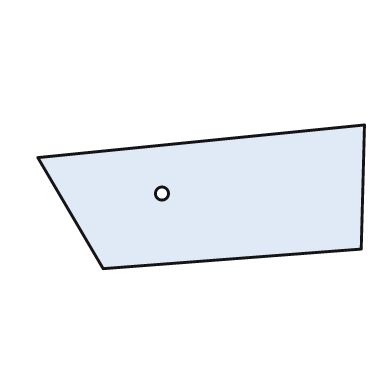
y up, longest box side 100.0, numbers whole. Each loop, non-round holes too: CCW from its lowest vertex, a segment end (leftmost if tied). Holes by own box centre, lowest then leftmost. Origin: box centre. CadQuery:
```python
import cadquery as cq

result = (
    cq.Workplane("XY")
    .moveTo(-30.0, -22.0)
    .lineTo(49.0, -16.0)
    .lineTo(50.0, 22.0)
    .lineTo(-50.0, 12.0)
    .close()
    .moveTo(-12.0, 1.0)
    .circle(2.0)
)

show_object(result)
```